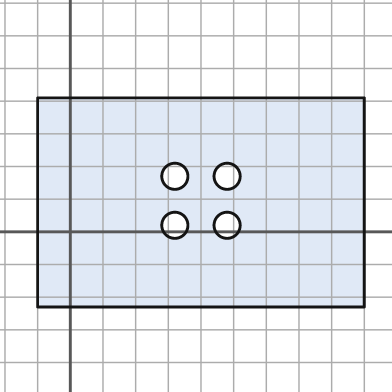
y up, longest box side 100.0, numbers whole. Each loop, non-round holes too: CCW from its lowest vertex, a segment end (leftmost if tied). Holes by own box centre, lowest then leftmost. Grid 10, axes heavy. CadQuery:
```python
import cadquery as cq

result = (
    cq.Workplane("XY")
    .moveTo(-10.0, -23.0)
    .lineTo(90.0, -23.0)
    .lineTo(90.0, 41.0)
    .lineTo(-10.0, 41.0)
    .close()
    .moveTo(32.0, 2.0)
    .circle(4.0)
    .moveTo(48.0, 2.0)
    .circle(4.0)
    .moveTo(32.0, 17.0)
    .circle(4.0)
    .moveTo(48.0, 17.0)
    .circle(4.0)
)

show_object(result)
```